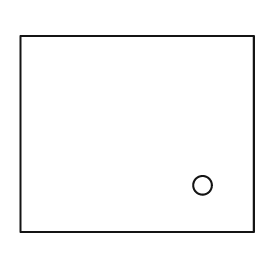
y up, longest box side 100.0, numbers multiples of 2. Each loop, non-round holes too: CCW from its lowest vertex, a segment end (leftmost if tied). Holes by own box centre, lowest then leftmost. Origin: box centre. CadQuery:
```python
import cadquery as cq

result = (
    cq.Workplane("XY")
    .moveTo(-50.0, -42.0)
    .lineTo(50.0, -42.0)
    .lineTo(50.0, 42.0)
    .lineTo(-50.0, 42.0)
    .close()
    .moveTo(28.0, -22.0)
    .circle(4.0)
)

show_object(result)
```